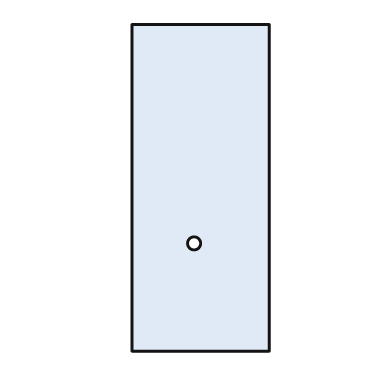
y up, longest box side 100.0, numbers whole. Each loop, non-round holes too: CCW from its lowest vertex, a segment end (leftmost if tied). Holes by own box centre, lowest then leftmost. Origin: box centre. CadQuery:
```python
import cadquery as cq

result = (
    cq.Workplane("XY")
    .moveTo(-21.0, -50.0)
    .lineTo(21.0, -50.0)
    .lineTo(21.0, 50.0)
    .lineTo(-21.0, 50.0)
    .close()
    .moveTo(-2.0, -17.0)
    .circle(2.0)
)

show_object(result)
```